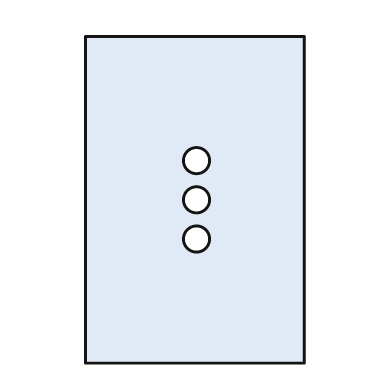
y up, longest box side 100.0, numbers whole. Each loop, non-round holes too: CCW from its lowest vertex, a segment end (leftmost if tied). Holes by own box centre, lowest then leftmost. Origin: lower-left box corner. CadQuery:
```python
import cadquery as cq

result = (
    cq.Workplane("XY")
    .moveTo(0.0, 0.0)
    .lineTo(67.0, 0.0)
    .lineTo(67.0, 100.0)
    .lineTo(0.0, 100.0)
    .close()
    .moveTo(34.0, 38.0)
    .circle(4.0)
    .moveTo(34.0, 50.0)
    .circle(4.0)
    .moveTo(34.0, 62.0)
    .circle(4.0)
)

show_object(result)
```